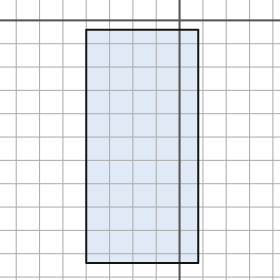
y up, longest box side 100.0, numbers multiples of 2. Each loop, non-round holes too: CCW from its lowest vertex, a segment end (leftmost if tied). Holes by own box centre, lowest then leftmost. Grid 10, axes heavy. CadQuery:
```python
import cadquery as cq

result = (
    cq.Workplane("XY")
    .moveTo(-40.0, -104.0)
    .lineTo(8.0, -104.0)
    .lineTo(8.0, -4.0)
    .lineTo(-40.0, -4.0)
    .close()
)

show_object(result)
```